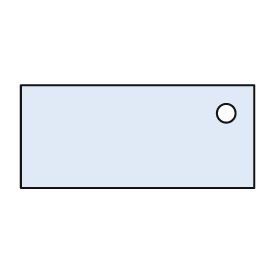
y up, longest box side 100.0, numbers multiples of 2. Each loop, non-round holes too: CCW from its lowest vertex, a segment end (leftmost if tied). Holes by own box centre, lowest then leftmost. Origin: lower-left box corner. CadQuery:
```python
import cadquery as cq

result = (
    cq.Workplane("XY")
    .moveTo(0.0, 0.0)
    .lineTo(100.0, 0.0)
    .lineTo(100.0, 44.0)
    .lineTo(0.0, 44.0)
    .close()
    .moveTo(88.0, 32.0)
    .circle(4.0)
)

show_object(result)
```